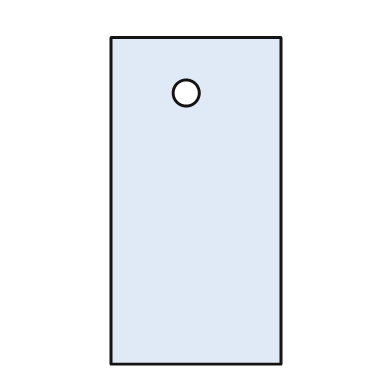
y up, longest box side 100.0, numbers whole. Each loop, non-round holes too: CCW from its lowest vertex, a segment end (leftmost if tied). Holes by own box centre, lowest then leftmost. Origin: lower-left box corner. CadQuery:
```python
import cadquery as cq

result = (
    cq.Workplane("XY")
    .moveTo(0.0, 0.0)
    .lineTo(52.0, 0.0)
    .lineTo(52.0, 100.0)
    .lineTo(0.0, 100.0)
    .close()
    .moveTo(23.0, 83.0)
    .circle(4.0)
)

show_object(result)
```